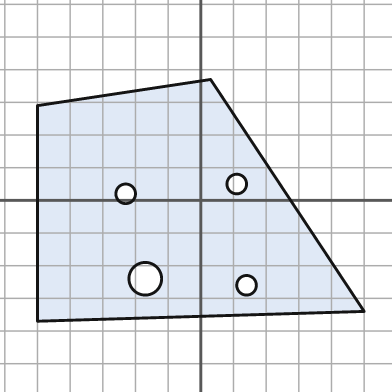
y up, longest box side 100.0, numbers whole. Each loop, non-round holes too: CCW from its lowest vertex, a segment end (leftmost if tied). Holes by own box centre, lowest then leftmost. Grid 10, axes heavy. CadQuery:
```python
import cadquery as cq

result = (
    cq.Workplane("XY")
    .moveTo(-50.0, -37.0)
    .lineTo(50.0, -34.0)
    .lineTo(3.0, 37.0)
    .lineTo(-50.0, 29.0)
    .close()
    .moveTo(14.0, -26.0)
    .circle(3.0)
    .moveTo(-17.0, -24.0)
    .circle(5.0)
    .moveTo(-23.0, 2.0)
    .circle(3.0)
    .moveTo(11.0, 5.0)
    .circle(3.0)
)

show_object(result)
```